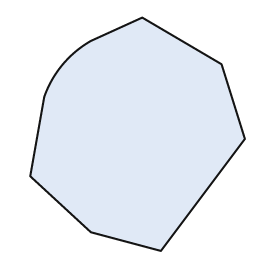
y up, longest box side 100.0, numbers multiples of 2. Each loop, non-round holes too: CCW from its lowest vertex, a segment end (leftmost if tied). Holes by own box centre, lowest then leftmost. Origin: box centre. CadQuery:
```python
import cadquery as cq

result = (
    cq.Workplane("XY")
    .moveTo(10.0, -50.0)
    .lineTo(46.0, -2.0)
    .lineTo(36.0, 30.0)
    .lineTo(2.0, 50.0)
    .lineTo(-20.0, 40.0)
    .threePointArc((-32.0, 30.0), (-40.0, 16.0))
    .lineTo(-46.0, -18.0)
    .lineTo(-20.0, -42.0)
    .close()
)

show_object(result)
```